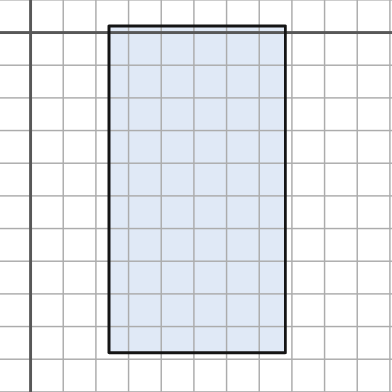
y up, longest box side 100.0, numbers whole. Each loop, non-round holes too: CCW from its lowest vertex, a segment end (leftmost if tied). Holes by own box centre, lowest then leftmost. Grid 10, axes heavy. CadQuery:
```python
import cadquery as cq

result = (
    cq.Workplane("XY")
    .moveTo(24.0, -98.0)
    .lineTo(78.0, -98.0)
    .lineTo(78.0, 2.0)
    .lineTo(24.0, 2.0)
    .close()
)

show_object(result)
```